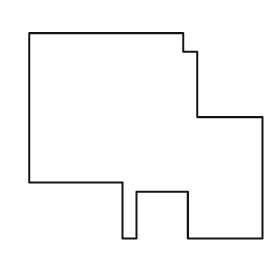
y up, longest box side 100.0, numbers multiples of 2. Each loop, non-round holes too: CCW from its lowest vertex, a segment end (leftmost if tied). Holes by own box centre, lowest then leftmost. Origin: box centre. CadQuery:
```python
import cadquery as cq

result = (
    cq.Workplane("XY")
    .moveTo(-10.0, -44.0)
    .lineTo(-4.0, -44.0)
    .lineTo(-4.0, -24.0)
    .lineTo(18.0, -24.0)
    .lineTo(18.0, -44.0)
    .lineTo(50.0, -44.0)
    .lineTo(50.0, 8.0)
    .lineTo(22.0, 8.0)
    .lineTo(22.0, 36.0)
    .lineTo(16.0, 36.0)
    .lineTo(16.0, 44.0)
    .lineTo(-50.0, 44.0)
    .lineTo(-50.0, -20.0)
    .lineTo(-10.0, -20.0)
    .close()
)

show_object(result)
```